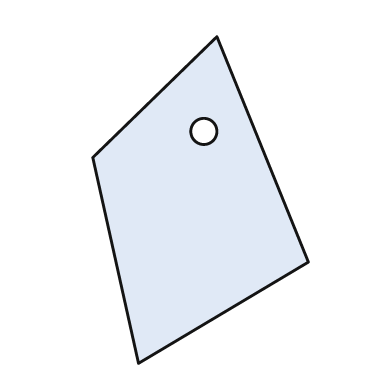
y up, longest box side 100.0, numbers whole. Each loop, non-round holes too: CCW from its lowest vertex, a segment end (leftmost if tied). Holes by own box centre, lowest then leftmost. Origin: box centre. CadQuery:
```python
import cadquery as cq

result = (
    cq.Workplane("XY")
    .moveTo(-19.0, -50.0)
    .lineTo(33.0, -19.0)
    .lineTo(5.0, 50.0)
    .lineTo(-33.0, 13.0)
    .close()
    .moveTo(1.0, 21.0)
    .circle(4.0)
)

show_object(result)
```